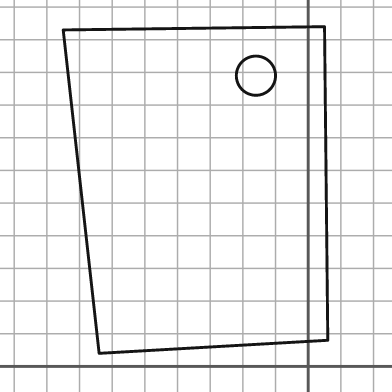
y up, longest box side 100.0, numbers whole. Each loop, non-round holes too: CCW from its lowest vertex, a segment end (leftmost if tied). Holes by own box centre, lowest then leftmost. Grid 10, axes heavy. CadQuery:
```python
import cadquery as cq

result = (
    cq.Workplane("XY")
    .moveTo(-64.0, 4.0)
    .lineTo(6.0, 8.0)
    .lineTo(5.0, 104.0)
    .lineTo(-75.0, 103.0)
    .close()
    .moveTo(-16.0, 89.0)
    .circle(6.0)
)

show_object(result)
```